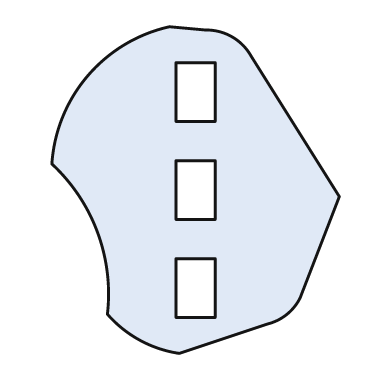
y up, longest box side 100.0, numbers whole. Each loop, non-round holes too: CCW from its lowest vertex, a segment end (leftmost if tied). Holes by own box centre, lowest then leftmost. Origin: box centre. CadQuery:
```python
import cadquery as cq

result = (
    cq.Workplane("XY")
    .moveTo(-5.0, -50.0)
    .lineTo(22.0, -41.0)
    .threePointArc((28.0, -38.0), (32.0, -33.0))
    .lineTo(44.0, -2.0)
    .lineTo(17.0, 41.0)
    .threePointArc((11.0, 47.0), (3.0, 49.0))
    .lineTo(-8.0, 50.0)
    .threePointArc((-33.0, 35.0), (-44.0, 8.0))
    .threePointArc((-30.0, -13.0), (-27.0, -38.0))
    .threePointArc((-17.0, -46.0), (-5.0, -50.0))
    .close()
    .moveTo(-6.0, -39.0)
    .lineTo(6.0, -39.0)
    .lineTo(6.0, -21.0)
    .lineTo(-6.0, -21.0)
    .close()
    .moveTo(-6.0, -9.0)
    .lineTo(6.0, -9.0)
    .lineTo(6.0, 9.0)
    .lineTo(-6.0, 9.0)
    .close()
    .moveTo(-6.0, 21.0)
    .lineTo(6.0, 21.0)
    .lineTo(6.0, 39.0)
    .lineTo(-6.0, 39.0)
    .close()
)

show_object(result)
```